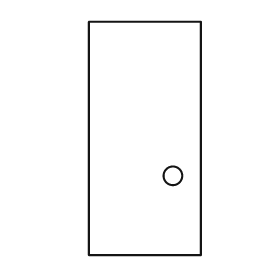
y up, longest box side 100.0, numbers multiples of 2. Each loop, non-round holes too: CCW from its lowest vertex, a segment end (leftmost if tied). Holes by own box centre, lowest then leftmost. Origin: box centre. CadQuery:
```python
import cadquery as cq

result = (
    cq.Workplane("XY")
    .moveTo(-24.0, -50.0)
    .lineTo(24.0, -50.0)
    .lineTo(24.0, 50.0)
    .lineTo(-24.0, 50.0)
    .close()
    .moveTo(12.0, -16.0)
    .circle(4.0)
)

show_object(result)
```